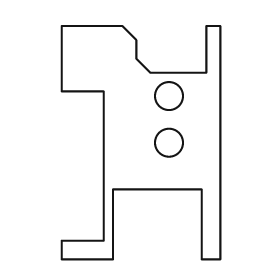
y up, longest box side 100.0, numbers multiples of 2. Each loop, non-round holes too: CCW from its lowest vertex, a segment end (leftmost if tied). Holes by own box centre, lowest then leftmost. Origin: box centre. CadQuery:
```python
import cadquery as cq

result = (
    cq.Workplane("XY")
    .moveTo(-34.0, -50.0)
    .lineTo(-12.0, -50.0)
    .lineTo(-12.0, -20.0)
    .lineTo(26.0, -20.0)
    .lineTo(26.0, -50.0)
    .lineTo(34.0, -50.0)
    .lineTo(34.0, 50.0)
    .lineTo(28.0, 50.0)
    .lineTo(28.0, 30.0)
    .lineTo(4.0, 30.0)
    .lineTo(-2.0, 36.0)
    .lineTo(-2.0, 44.0)
    .lineTo(-8.0, 50.0)
    .lineTo(-34.0, 50.0)
    .lineTo(-34.0, 22.0)
    .lineTo(-16.0, 22.0)
    .lineTo(-16.0, -42.0)
    .lineTo(-34.0, -42.0)
    .close()
    .moveTo(12.0, 0.0)
    .circle(6.0)
    .moveTo(12.0, 20.0)
    .circle(6.0)
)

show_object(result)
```